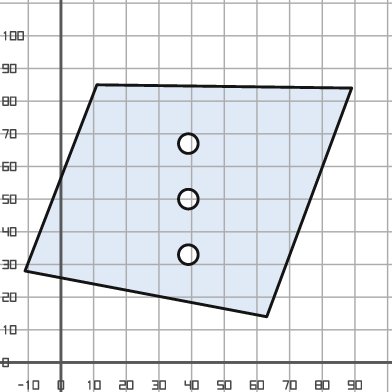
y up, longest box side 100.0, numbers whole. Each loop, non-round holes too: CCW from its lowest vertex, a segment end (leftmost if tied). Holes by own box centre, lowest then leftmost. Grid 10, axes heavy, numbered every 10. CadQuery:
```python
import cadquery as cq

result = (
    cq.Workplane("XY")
    .moveTo(63.0, 14.0)
    .lineTo(89.0, 84.0)
    .lineTo(11.0, 85.0)
    .lineTo(-11.0, 28.0)
    .close()
    .moveTo(39.0, 33.0)
    .circle(3.0)
    .moveTo(39.0, 50.0)
    .circle(3.0)
    .moveTo(39.0, 67.0)
    .circle(3.0)
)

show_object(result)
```